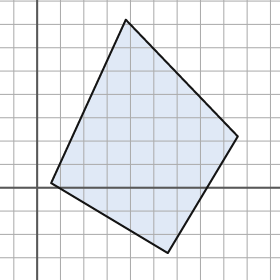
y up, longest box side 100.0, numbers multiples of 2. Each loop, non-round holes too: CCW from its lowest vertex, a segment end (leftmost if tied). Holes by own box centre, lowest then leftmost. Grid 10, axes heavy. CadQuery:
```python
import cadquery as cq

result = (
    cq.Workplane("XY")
    .moveTo(56.0, -28.0)
    .lineTo(86.0, 22.0)
    .lineTo(38.0, 72.0)
    .lineTo(6.0, 2.0)
    .close()
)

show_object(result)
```